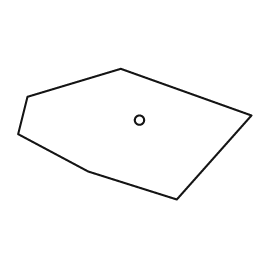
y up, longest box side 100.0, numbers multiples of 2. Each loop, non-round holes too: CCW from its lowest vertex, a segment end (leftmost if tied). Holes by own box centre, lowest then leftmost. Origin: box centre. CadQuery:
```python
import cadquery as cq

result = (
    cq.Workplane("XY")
    .moveTo(18.0, -28.0)
    .lineTo(50.0, 8.0)
    .lineTo(-6.0, 28.0)
    .lineTo(-46.0, 16.0)
    .lineTo(-50.0, 0.0)
    .lineTo(-20.0, -16.0)
    .close()
    .moveTo(2.0, 6.0)
    .circle(2.0)
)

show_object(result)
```